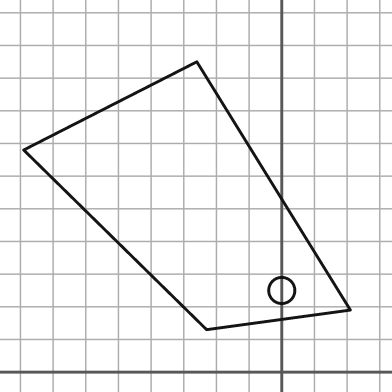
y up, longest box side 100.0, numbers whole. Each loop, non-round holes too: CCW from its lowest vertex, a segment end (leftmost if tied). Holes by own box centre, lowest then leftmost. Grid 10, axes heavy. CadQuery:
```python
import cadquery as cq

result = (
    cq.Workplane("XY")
    .moveTo(-23.0, 13.0)
    .lineTo(21.0, 19.0)
    .lineTo(-26.0, 95.0)
    .lineTo(-79.0, 68.0)
    .close()
    .moveTo(0.0, 25.0)
    .circle(4.0)
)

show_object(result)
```